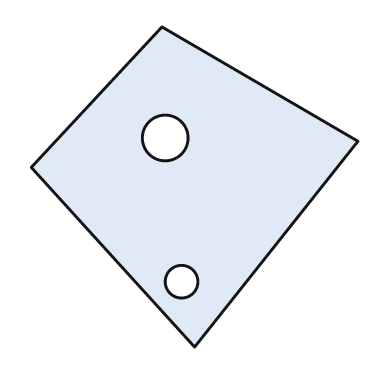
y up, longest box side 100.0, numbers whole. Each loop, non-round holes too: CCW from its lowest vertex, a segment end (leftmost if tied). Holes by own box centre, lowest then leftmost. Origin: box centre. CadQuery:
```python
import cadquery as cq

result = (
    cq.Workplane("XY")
    .moveTo(0.0, -49.0)
    .lineTo(50.0, 14.0)
    .lineTo(-10.0, 49.0)
    .lineTo(-50.0, 6.0)
    .close()
    .moveTo(-4.0, -29.0)
    .circle(5.0)
    .moveTo(-9.0, 15.0)
    .circle(7.0)
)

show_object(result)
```